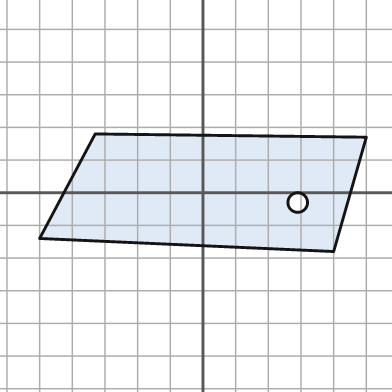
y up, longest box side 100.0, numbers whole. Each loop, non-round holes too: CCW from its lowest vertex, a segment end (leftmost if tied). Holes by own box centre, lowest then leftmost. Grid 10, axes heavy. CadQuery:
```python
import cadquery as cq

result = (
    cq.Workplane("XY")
    .moveTo(40.0, -18.0)
    .lineTo(50.0, 17.0)
    .lineTo(-33.0, 18.0)
    .lineTo(-50.0, -14.0)
    .close()
    .moveTo(29.0, -3.0)
    .circle(3.0)
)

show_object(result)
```